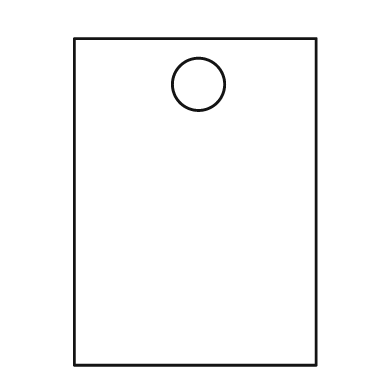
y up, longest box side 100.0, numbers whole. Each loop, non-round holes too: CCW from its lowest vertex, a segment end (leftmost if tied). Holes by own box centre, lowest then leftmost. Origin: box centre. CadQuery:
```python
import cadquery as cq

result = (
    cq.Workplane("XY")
    .moveTo(-37.0, -50.0)
    .lineTo(37.0, -50.0)
    .lineTo(37.0, 50.0)
    .lineTo(-37.0, 50.0)
    .close()
    .moveTo(1.0, 36.0)
    .circle(8.0)
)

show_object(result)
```